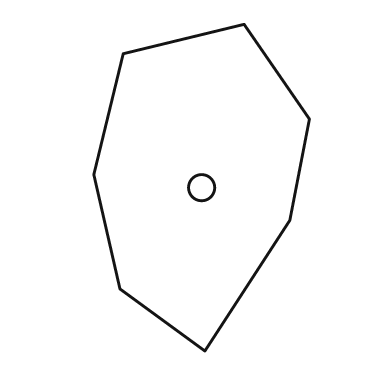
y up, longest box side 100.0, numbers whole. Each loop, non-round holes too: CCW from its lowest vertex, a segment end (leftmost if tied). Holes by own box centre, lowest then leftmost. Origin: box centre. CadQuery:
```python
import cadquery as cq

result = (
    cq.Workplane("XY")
    .moveTo(1.0, -50.0)
    .lineTo(27.0, -10.0)
    .lineTo(33.0, 21.0)
    .lineTo(13.0, 50.0)
    .lineTo(-24.0, 41.0)
    .lineTo(-33.0, 4.0)
    .lineTo(-25.0, -31.0)
    .close()
    .moveTo(0.0, 0.0)
    .circle(4.0)
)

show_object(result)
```